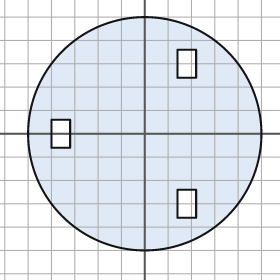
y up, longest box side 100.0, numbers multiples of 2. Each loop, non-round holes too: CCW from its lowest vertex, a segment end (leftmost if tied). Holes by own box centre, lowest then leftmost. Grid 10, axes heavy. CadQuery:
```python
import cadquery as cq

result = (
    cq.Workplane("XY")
    .moveTo(0.0, 0.0)
    .circle(50.0)
    .moveTo(14.0, -36.0)
    .lineTo(22.0, -36.0)
    .lineTo(22.0, -24.0)
    .lineTo(14.0, -24.0)
    .close()
    .moveTo(-40.0, -6.0)
    .lineTo(-32.0, -6.0)
    .lineTo(-32.0, 6.0)
    .lineTo(-40.0, 6.0)
    .close()
    .moveTo(14.0, 24.0)
    .lineTo(22.0, 24.0)
    .lineTo(22.0, 36.0)
    .lineTo(14.0, 36.0)
    .close()
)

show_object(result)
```